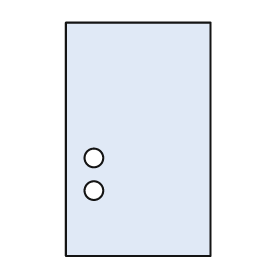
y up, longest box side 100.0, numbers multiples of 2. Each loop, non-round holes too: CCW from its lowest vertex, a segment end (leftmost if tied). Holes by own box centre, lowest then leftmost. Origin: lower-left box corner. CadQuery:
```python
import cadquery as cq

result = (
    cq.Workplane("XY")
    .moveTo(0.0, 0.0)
    .lineTo(62.0, 0.0)
    .lineTo(62.0, 100.0)
    .lineTo(0.0, 100.0)
    .close()
    .moveTo(12.0, 28.0)
    .circle(4.0)
    .moveTo(12.0, 42.0)
    .circle(4.0)
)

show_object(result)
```